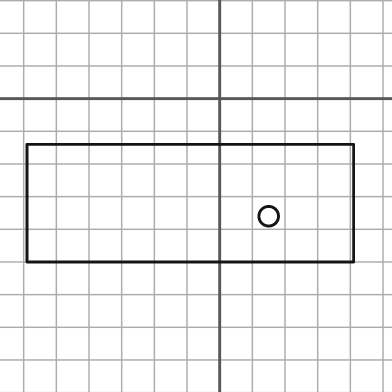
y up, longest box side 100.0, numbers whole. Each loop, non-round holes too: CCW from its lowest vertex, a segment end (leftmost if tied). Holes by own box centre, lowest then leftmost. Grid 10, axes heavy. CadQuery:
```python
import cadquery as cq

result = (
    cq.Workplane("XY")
    .moveTo(-59.0, -50.0)
    .lineTo(41.0, -50.0)
    .lineTo(41.0, -14.0)
    .lineTo(-59.0, -14.0)
    .close()
    .moveTo(15.0, -36.0)
    .circle(3.0)
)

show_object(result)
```